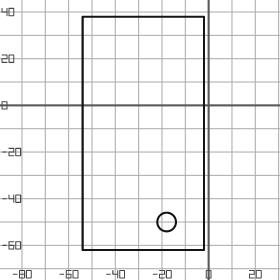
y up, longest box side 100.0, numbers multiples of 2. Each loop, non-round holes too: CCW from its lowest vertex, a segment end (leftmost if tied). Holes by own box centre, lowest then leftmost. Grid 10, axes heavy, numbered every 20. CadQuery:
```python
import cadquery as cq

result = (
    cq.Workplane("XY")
    .moveTo(-54.0, -62.0)
    .lineTo(-2.0, -62.0)
    .lineTo(-2.0, 38.0)
    .lineTo(-54.0, 38.0)
    .close()
    .moveTo(-18.0, -50.0)
    .circle(4.0)
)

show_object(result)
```